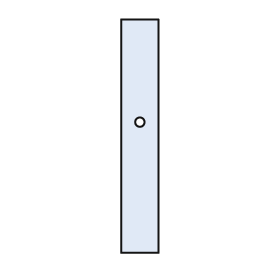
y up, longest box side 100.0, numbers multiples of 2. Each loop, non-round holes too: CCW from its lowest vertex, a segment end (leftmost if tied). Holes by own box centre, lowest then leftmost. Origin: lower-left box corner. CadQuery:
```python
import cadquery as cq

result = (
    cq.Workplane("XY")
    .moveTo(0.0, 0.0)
    .lineTo(16.0, 0.0)
    .lineTo(16.0, 100.0)
    .lineTo(0.0, 100.0)
    .close()
    .moveTo(8.0, 56.0)
    .circle(2.0)
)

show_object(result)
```